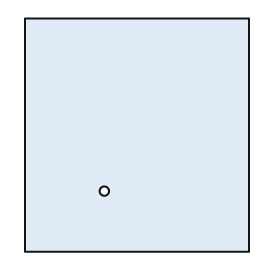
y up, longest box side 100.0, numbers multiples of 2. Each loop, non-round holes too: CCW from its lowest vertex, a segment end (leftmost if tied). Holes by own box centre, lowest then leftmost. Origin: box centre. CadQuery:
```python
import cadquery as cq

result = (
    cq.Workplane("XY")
    .moveTo(-48.0, -50.0)
    .lineTo(48.0, -50.0)
    .lineTo(48.0, 50.0)
    .lineTo(-48.0, 50.0)
    .close()
    .moveTo(-14.0, -24.0)
    .circle(2.0)
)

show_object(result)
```